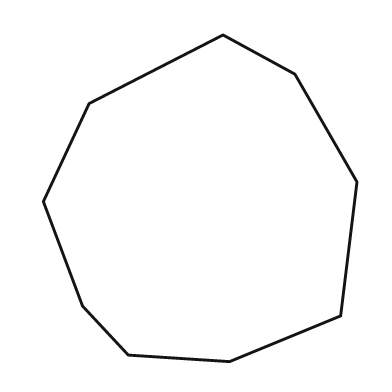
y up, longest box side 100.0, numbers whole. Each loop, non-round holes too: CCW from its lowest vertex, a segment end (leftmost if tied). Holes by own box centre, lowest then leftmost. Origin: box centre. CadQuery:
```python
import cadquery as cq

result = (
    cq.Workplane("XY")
    .moveTo(9.0, -50.0)
    .lineTo(43.0, -36.0)
    .lineTo(48.0, 5.0)
    .lineTo(29.0, 38.0)
    .lineTo(7.0, 50.0)
    .lineTo(-34.0, 29.0)
    .lineTo(-48.0, -1.0)
    .lineTo(-36.0, -33.0)
    .lineTo(-22.0, -48.0)
    .close()
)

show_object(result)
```